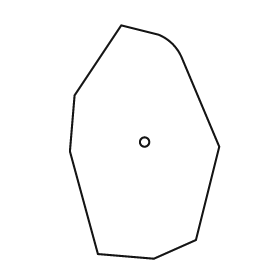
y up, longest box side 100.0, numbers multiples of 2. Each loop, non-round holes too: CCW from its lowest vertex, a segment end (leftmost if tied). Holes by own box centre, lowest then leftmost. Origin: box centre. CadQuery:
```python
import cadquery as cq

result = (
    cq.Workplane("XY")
    .moveTo(4.0, -50.0)
    .lineTo(22.0, -42.0)
    .lineTo(32.0, -2.0)
    .lineTo(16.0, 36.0)
    .threePointArc((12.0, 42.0), (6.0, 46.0))
    .lineTo(-10.0, 50.0)
    .lineTo(-30.0, 20.0)
    .lineTo(-32.0, -4.0)
    .lineTo(-20.0, -48.0)
    .close()
    .moveTo(0.0, 0.0)
    .circle(2.0)
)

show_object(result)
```